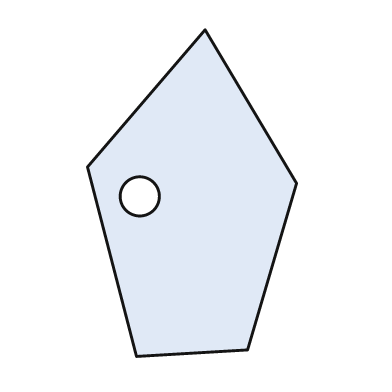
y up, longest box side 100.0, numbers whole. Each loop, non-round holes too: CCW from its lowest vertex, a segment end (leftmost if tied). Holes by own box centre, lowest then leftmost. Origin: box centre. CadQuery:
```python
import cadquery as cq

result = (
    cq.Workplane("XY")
    .moveTo(-17.0, -50.0)
    .lineTo(17.0, -48.0)
    .lineTo(32.0, 3.0)
    .lineTo(4.0, 50.0)
    .lineTo(-32.0, 8.0)
    .close()
    .moveTo(-16.0, -1.0)
    .circle(6.0)
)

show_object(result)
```